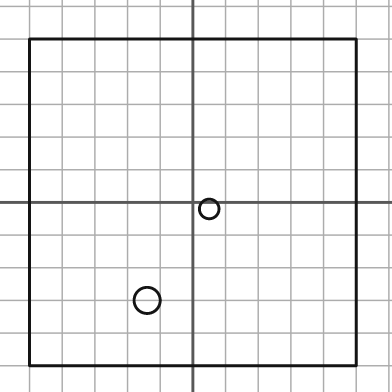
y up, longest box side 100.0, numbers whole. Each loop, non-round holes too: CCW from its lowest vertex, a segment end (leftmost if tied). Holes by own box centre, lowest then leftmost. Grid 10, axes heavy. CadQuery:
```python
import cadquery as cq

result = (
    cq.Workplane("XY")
    .moveTo(-50.0, -50.0)
    .lineTo(50.0, -50.0)
    .lineTo(50.0, 50.0)
    .lineTo(-50.0, 50.0)
    .close()
    .moveTo(-14.0, -30.0)
    .circle(4.0)
    .moveTo(5.0, -2.0)
    .circle(3.0)
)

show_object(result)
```